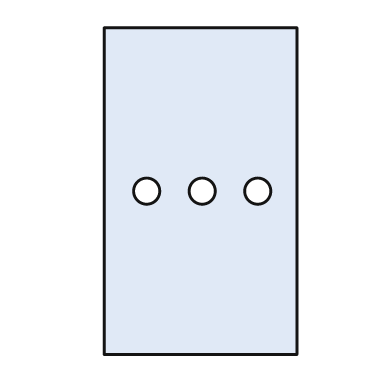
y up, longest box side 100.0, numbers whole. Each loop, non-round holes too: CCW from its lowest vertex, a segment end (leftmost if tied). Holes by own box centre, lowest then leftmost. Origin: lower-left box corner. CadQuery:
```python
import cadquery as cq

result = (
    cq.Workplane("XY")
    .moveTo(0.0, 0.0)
    .lineTo(59.0, 0.0)
    .lineTo(59.0, 100.0)
    .lineTo(0.0, 100.0)
    .close()
    .moveTo(13.0, 50.0)
    .circle(4.0)
    .moveTo(30.0, 50.0)
    .circle(4.0)
    .moveTo(47.0, 50.0)
    .circle(4.0)
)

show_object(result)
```